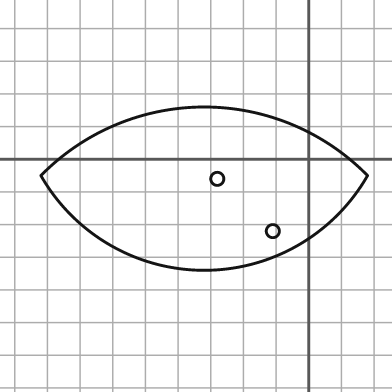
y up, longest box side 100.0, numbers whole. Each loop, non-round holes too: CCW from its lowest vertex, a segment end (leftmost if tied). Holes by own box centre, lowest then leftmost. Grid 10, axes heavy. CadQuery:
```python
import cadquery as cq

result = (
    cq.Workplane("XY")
    .moveTo(-82.0, -5.0)
    .threePointArc((-32.0, -34.0), (18.0, -5.0))
    .threePointArc((-32.0, 16.0), (-82.0, -5.0))
    .close()
    .moveTo(-11.0, -22.0)
    .circle(2.0)
    .moveTo(-28.0, -6.0)
    .circle(2.0)
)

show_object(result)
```